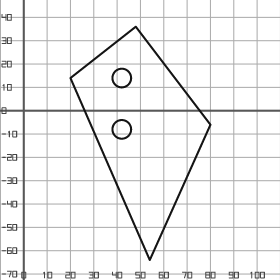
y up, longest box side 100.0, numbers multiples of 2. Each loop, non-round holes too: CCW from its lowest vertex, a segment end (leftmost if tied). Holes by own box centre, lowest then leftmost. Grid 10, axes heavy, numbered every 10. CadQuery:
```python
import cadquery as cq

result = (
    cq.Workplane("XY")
    .moveTo(54.0, -64.0)
    .lineTo(80.0, -6.0)
    .lineTo(48.0, 36.0)
    .lineTo(20.0, 14.0)
    .close()
    .moveTo(42.0, -8.0)
    .circle(4.0)
    .moveTo(42.0, 14.0)
    .circle(4.0)
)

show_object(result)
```